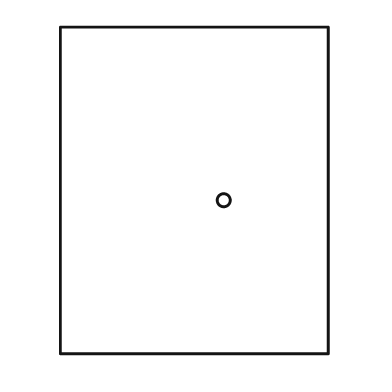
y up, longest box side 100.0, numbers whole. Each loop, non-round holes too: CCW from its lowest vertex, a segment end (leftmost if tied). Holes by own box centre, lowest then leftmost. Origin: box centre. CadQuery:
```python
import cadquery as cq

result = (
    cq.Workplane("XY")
    .moveTo(-41.0, -50.0)
    .lineTo(41.0, -50.0)
    .lineTo(41.0, 50.0)
    .lineTo(-41.0, 50.0)
    .close()
    .moveTo(9.0, -3.0)
    .circle(2.0)
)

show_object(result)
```